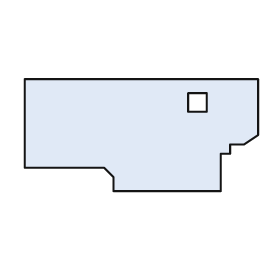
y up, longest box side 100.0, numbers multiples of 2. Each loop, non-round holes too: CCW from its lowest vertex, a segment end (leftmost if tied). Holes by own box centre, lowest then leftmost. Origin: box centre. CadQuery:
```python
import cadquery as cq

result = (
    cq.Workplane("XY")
    .moveTo(-12.0, -24.0)
    .lineTo(34.0, -24.0)
    .lineTo(34.0, -8.0)
    .lineTo(38.0, -8.0)
    .lineTo(38.0, -4.0)
    .lineTo(44.0, -4.0)
    .lineTo(50.0, 0.0)
    .lineTo(50.0, 24.0)
    .lineTo(-50.0, 24.0)
    .lineTo(-50.0, -14.0)
    .lineTo(-16.0, -14.0)
    .lineTo(-12.0, -18.0)
    .close()
    .moveTo(20.0, 10.0)
    .lineTo(28.0, 10.0)
    .lineTo(28.0, 18.0)
    .lineTo(20.0, 18.0)
    .close()
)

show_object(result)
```